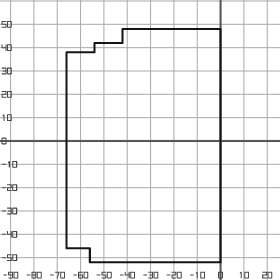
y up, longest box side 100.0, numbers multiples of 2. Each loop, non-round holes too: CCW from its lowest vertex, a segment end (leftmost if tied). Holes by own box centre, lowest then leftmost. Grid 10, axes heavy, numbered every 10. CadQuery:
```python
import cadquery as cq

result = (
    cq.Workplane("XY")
    .moveTo(-56.0, -52.0)
    .lineTo(0.0, -52.0)
    .lineTo(0.0, 48.0)
    .lineTo(-42.0, 48.0)
    .lineTo(-42.0, 42.0)
    .lineTo(-54.0, 42.0)
    .lineTo(-54.0, 38.0)
    .lineTo(-66.0, 38.0)
    .lineTo(-66.0, -46.0)
    .lineTo(-56.0, -46.0)
    .close()
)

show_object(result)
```